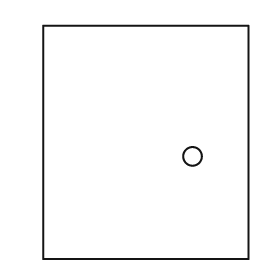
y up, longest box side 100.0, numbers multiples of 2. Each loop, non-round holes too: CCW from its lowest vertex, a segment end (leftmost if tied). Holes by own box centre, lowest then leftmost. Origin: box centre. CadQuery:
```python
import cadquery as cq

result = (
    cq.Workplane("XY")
    .moveTo(-44.0, -50.0)
    .lineTo(44.0, -50.0)
    .lineTo(44.0, 50.0)
    .lineTo(-44.0, 50.0)
    .close()
    .moveTo(20.0, -6.0)
    .circle(4.0)
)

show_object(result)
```